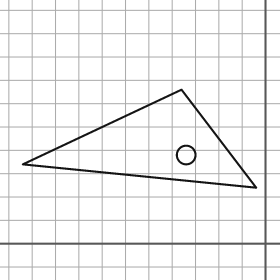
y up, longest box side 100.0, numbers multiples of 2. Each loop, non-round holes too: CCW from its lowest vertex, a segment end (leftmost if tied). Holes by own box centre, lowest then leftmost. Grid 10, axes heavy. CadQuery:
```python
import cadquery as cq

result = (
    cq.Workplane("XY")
    .moveTo(-4.0, 24.0)
    .lineTo(-36.0, 66.0)
    .lineTo(-104.0, 34.0)
    .close()
    .moveTo(-34.0, 38.0)
    .circle(4.0)
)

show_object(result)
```